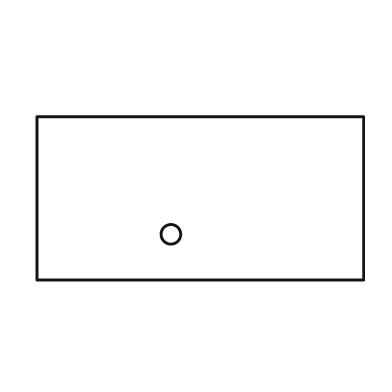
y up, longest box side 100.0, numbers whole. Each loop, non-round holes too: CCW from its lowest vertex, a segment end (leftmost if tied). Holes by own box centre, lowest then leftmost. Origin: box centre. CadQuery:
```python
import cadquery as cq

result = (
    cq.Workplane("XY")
    .moveTo(-50.0, -25.0)
    .lineTo(50.0, -25.0)
    .lineTo(50.0, 25.0)
    .lineTo(-50.0, 25.0)
    .close()
    .moveTo(-9.0, -11.0)
    .circle(3.0)
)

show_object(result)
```